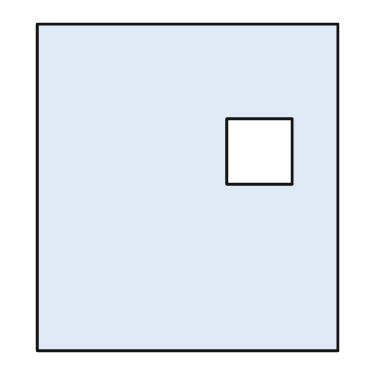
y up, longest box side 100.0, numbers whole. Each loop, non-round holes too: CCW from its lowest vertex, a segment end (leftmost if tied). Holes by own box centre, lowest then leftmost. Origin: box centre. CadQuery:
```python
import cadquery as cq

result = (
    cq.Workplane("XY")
    .moveTo(-46.0, -50.0)
    .lineTo(46.0, -50.0)
    .lineTo(46.0, 50.0)
    .lineTo(-46.0, 50.0)
    .close()
    .moveTo(12.0, 1.0)
    .lineTo(32.0, 1.0)
    .lineTo(32.0, 21.0)
    .lineTo(12.0, 21.0)
    .close()
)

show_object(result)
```